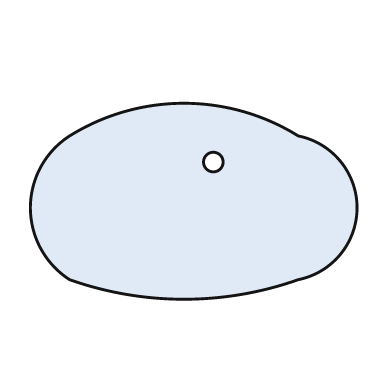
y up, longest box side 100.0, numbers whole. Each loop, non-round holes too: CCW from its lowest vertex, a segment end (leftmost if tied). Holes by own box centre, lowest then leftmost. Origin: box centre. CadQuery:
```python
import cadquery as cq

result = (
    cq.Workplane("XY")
    .moveTo(-38.0, -24.0)
    .threePointArc((-3.0, -30.0), (32.0, -24.0))
    .threePointArc((50.0, -2.0), (32.0, 20.0))
    .threePointArc((-3.0, 30.0), (-38.0, 20.0))
    .threePointArc((-50.0, -2.0), (-38.0, -24.0))
    .close()
    .moveTo(6.0, 12.0)
    .circle(3.0)
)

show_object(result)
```